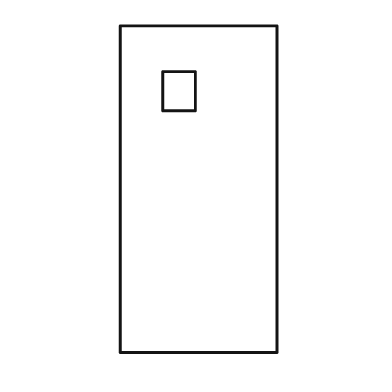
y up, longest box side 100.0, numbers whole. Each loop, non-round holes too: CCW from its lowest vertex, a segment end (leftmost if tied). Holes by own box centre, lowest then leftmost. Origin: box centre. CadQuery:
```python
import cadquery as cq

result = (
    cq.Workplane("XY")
    .moveTo(-24.0, -50.0)
    .lineTo(24.0, -50.0)
    .lineTo(24.0, 50.0)
    .lineTo(-24.0, 50.0)
    .close()
    .moveTo(-11.0, 24.0)
    .lineTo(-1.0, 24.0)
    .lineTo(-1.0, 36.0)
    .lineTo(-11.0, 36.0)
    .close()
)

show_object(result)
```